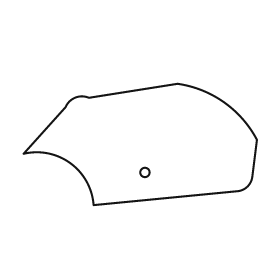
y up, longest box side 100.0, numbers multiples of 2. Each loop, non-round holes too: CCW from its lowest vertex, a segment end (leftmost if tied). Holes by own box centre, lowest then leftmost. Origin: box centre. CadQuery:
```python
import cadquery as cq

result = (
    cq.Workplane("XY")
    .moveTo(-20.0, -26.0)
    .lineTo(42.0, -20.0)
    .threePointArc((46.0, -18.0), (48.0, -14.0))
    .lineTo(50.0, 2.0)
    .threePointArc((36.0, 18.0), (16.0, 26.0))
    .lineTo(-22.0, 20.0)
    .threePointArc((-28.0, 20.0), (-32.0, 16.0))
    .lineTo(-50.0, -4.0)
    .threePointArc((-30.0, -8.0), (-20.0, -26.0))
    .close()
    .moveTo(2.0, -12.0)
    .circle(2.0)
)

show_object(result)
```